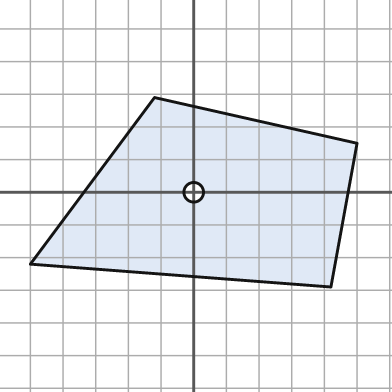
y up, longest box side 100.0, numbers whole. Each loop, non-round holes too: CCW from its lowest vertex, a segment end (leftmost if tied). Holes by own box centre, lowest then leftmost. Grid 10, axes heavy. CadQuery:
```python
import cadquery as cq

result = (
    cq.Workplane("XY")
    .moveTo(42.0, -29.0)
    .lineTo(50.0, 15.0)
    .lineTo(-12.0, 29.0)
    .lineTo(-50.0, -22.0)
    .close()
    .moveTo(0.0, 0.0)
    .circle(3.0)
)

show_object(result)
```